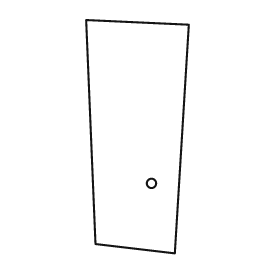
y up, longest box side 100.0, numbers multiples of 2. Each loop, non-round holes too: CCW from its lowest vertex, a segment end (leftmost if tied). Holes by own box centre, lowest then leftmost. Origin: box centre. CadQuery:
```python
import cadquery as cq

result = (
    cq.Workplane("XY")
    .moveTo(16.0, -50.0)
    .lineTo(22.0, 48.0)
    .lineTo(-22.0, 50.0)
    .lineTo(-18.0, -46.0)
    .close()
    .moveTo(6.0, -20.0)
    .circle(2.0)
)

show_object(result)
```